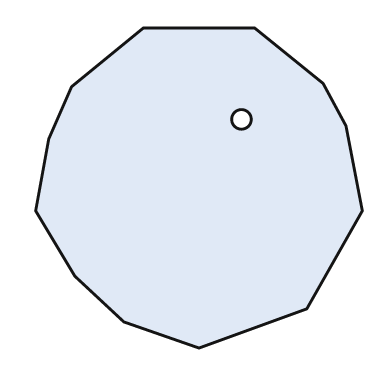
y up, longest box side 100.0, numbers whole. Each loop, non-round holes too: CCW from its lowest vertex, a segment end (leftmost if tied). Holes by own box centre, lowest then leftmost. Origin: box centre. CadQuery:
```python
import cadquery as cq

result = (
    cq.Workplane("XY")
    .moveTo(0.0, -49.0)
    .lineTo(33.0, -37.0)
    .lineTo(50.0, -7.0)
    .lineTo(45.0, 19.0)
    .lineTo(38.0, 32.0)
    .lineTo(17.0, 49.0)
    .lineTo(-17.0, 49.0)
    .lineTo(-39.0, 31.0)
    .lineTo(-46.0, 15.0)
    .lineTo(-50.0, -7.0)
    .lineTo(-38.0, -27.0)
    .lineTo(-23.0, -41.0)
    .close()
    .moveTo(13.0, 21.0)
    .circle(3.0)
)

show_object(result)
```